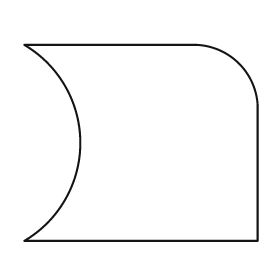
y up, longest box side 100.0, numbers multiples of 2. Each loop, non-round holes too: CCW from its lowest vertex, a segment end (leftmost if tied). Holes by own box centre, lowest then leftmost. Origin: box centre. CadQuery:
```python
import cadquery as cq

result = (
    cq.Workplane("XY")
    .moveTo(-50.0, -42.0)
    .lineTo(50.0, -42.0)
    .lineTo(50.0, 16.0)
    .threePointArc((42.0, 34.0), (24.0, 42.0))
    .lineTo(-50.0, 42.0)
    .threePointArc((-26.0, 0.0), (-50.0, -42.0))
    .close()
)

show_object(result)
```